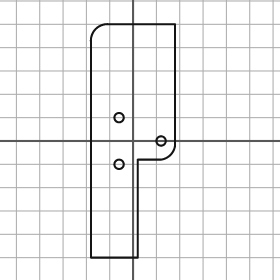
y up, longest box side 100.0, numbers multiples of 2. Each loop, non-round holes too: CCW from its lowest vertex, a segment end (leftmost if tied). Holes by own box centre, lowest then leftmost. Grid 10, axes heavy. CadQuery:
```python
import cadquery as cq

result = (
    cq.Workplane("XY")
    .moveTo(-18.0, -50.0)
    .lineTo(2.0, -50.0)
    .lineTo(2.0, -8.0)
    .lineTo(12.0, -8.0)
    .threePointArc((16.0, -6.0), (18.0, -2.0))
    .lineTo(18.0, 50.0)
    .lineTo(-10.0, 50.0)
    .threePointArc((-16.0, 48.0), (-18.0, 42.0))
    .close()
    .moveTo(-6.0, -10.0)
    .circle(2.0)
    .moveTo(12.0, 0.0)
    .circle(2.0)
    .moveTo(-6.0, 10.0)
    .circle(2.0)
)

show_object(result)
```